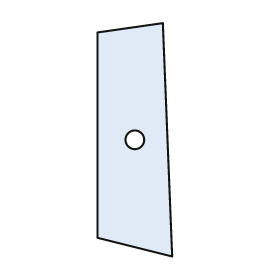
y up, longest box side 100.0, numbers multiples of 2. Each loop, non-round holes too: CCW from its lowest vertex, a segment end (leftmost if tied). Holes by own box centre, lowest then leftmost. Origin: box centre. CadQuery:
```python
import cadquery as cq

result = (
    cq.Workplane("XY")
    .moveTo(16.0, -50.0)
    .lineTo(12.0, 50.0)
    .lineTo(-16.0, 46.0)
    .lineTo(-16.0, -42.0)
    .close()
    .moveTo(0.0, 0.0)
    .circle(4.0)
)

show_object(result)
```